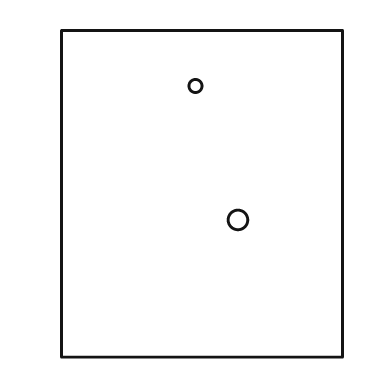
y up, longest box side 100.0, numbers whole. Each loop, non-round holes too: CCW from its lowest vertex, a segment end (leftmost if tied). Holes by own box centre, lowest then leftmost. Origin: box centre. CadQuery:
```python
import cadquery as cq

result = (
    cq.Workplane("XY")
    .moveTo(-43.0, -50.0)
    .lineTo(43.0, -50.0)
    .lineTo(43.0, 50.0)
    .lineTo(-43.0, 50.0)
    .close()
    .moveTo(11.0, -8.0)
    .circle(3.0)
    .moveTo(-2.0, 33.0)
    .circle(2.0)
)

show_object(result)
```